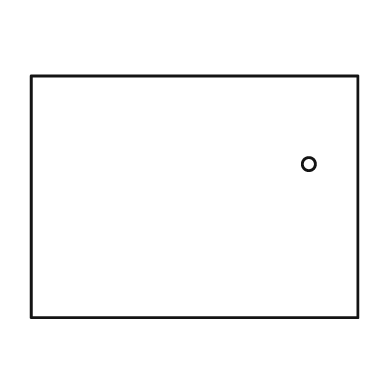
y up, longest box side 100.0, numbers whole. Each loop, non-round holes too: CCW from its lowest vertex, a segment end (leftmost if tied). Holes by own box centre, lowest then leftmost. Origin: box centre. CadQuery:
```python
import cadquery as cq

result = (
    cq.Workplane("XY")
    .moveTo(-50.0, -37.0)
    .lineTo(50.0, -37.0)
    .lineTo(50.0, 37.0)
    .lineTo(-50.0, 37.0)
    .close()
    .moveTo(35.0, 10.0)
    .circle(2.0)
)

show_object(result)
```